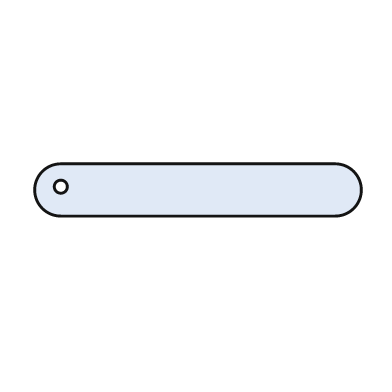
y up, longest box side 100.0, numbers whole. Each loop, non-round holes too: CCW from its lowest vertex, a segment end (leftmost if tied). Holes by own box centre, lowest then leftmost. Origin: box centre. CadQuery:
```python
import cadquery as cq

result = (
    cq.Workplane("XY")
    .moveTo(-42.0, -8.0)
    .lineTo(42.0, -8.0)
    .threePointArc((50.0, 0.0), (42.0, 8.0))
    .lineTo(-42.0, 8.0)
    .threePointArc((-50.0, 0.0), (-42.0, -8.0))
    .close()
    .moveTo(-42.0, 1.0)
    .circle(2.0)
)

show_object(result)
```